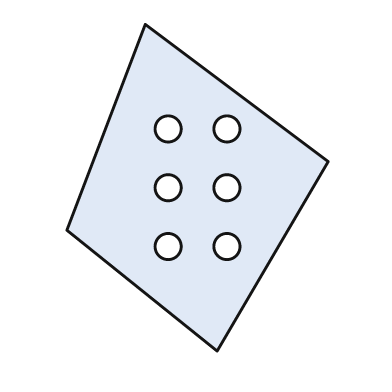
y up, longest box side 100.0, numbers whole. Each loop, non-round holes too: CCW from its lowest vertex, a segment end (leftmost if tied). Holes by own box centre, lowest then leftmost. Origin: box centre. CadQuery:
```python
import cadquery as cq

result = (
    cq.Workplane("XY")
    .moveTo(6.0, -50.0)
    .lineTo(40.0, 8.0)
    .lineTo(-16.0, 50.0)
    .lineTo(-40.0, -13.0)
    .close()
    .moveTo(-9.0, -18.0)
    .circle(4.0)
    .moveTo(9.0, -18.0)
    .circle(4.0)
    .moveTo(-9.0, 0.0)
    .circle(4.0)
    .moveTo(9.0, 0.0)
    .circle(4.0)
    .moveTo(-9.0, 18.0)
    .circle(4.0)
    .moveTo(9.0, 18.0)
    .circle(4.0)
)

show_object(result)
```